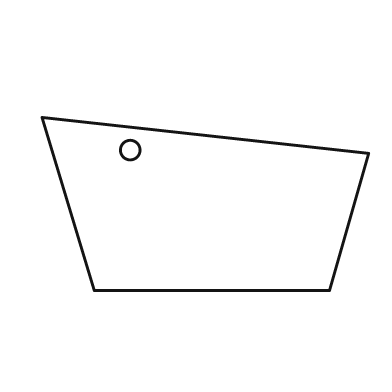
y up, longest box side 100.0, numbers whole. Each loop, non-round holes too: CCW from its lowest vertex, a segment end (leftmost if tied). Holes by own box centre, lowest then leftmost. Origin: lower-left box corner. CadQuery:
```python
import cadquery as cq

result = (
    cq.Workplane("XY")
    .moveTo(16.0, 0.0)
    .lineTo(88.0, 0.0)
    .lineTo(100.0, 42.0)
    .lineTo(0.0, 53.0)
    .close()
    .moveTo(27.0, 43.0)
    .circle(3.0)
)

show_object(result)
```